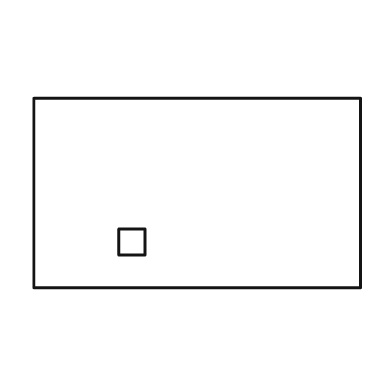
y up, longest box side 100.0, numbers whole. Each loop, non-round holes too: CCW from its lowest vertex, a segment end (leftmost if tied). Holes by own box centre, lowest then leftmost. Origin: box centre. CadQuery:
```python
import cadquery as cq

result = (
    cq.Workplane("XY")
    .moveTo(-50.0, -29.0)
    .lineTo(50.0, -29.0)
    .lineTo(50.0, 29.0)
    .lineTo(-50.0, 29.0)
    .close()
    .moveTo(-24.0, -19.0)
    .lineTo(-16.0, -19.0)
    .lineTo(-16.0, -11.0)
    .lineTo(-24.0, -11.0)
    .close()
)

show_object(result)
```